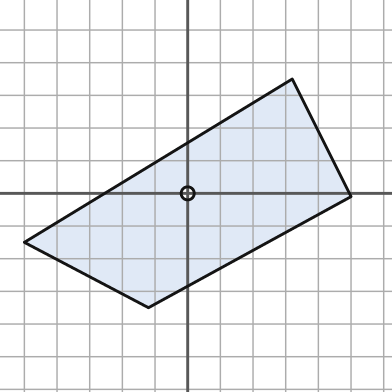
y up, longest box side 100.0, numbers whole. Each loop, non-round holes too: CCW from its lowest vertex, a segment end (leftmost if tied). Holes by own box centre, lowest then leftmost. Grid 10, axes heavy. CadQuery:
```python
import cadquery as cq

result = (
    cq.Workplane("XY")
    .moveTo(-12.0, -35.0)
    .lineTo(50.0, -1.0)
    .lineTo(32.0, 35.0)
    .lineTo(-50.0, -15.0)
    .close()
    .moveTo(0.0, 0.0)
    .circle(2.0)
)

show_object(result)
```